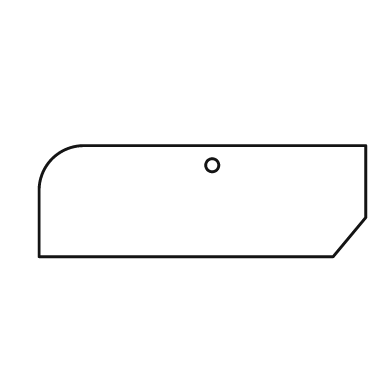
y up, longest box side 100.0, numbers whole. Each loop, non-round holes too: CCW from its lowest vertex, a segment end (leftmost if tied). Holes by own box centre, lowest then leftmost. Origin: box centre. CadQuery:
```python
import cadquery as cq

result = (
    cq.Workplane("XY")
    .moveTo(-50.0, -17.0)
    .lineTo(40.0, -17.0)
    .lineTo(50.0, -5.0)
    .lineTo(50.0, 17.0)
    .lineTo(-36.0, 17.0)
    .threePointArc((-46.0, 13.0), (-50.0, 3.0))
    .close()
    .moveTo(3.0, 11.0)
    .circle(2.0)
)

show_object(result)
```